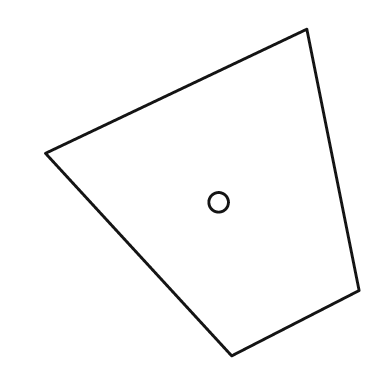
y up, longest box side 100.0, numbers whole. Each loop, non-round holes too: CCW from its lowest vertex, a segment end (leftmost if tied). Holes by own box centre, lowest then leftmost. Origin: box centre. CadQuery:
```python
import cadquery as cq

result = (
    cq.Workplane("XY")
    .moveTo(9.0, -50.0)
    .lineTo(48.0, -30.0)
    .lineTo(32.0, 50.0)
    .lineTo(-48.0, 12.0)
    .close()
    .moveTo(5.0, -3.0)
    .circle(3.0)
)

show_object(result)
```